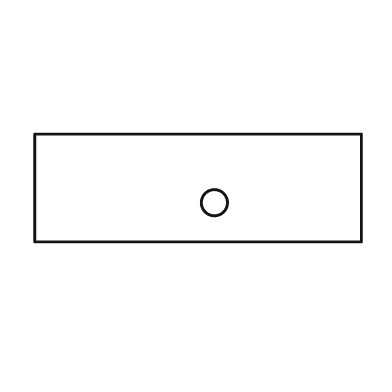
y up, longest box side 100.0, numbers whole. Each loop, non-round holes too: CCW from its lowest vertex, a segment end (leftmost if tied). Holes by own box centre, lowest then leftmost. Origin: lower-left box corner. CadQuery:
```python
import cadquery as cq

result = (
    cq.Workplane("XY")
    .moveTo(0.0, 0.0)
    .lineTo(100.0, 0.0)
    .lineTo(100.0, 33.0)
    .lineTo(0.0, 33.0)
    .close()
    .moveTo(55.0, 12.0)
    .circle(4.0)
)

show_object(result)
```